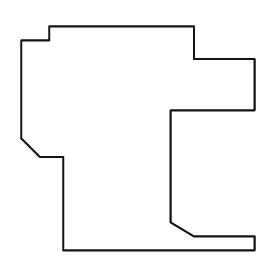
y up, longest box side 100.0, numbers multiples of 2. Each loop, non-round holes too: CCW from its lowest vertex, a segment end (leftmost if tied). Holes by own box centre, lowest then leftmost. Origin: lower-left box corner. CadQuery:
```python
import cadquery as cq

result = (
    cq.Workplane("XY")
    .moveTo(18.0, 0.0)
    .lineTo(100.0, 0.0)
    .lineTo(100.0, 6.0)
    .lineTo(74.0, 6.0)
    .lineTo(64.0, 12.0)
    .lineTo(64.0, 60.0)
    .lineTo(100.0, 60.0)
    .lineTo(100.0, 82.0)
    .lineTo(74.0, 82.0)
    .lineTo(74.0, 96.0)
    .lineTo(12.0, 96.0)
    .lineTo(12.0, 90.0)
    .lineTo(0.0, 90.0)
    .lineTo(0.0, 48.0)
    .lineTo(8.0, 40.0)
    .lineTo(18.0, 40.0)
    .close()
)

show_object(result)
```